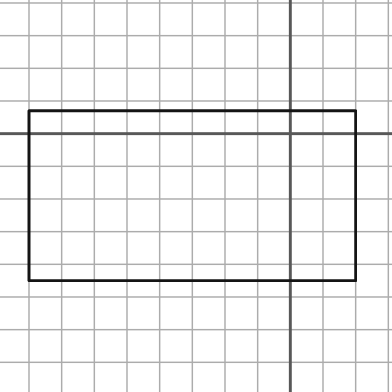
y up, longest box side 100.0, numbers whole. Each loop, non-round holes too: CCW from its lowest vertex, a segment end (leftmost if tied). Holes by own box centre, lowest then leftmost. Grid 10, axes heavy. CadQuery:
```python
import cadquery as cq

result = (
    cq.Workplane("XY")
    .moveTo(-80.0, -45.0)
    .lineTo(20.0, -45.0)
    .lineTo(20.0, 7.0)
    .lineTo(-80.0, 7.0)
    .close()
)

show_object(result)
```